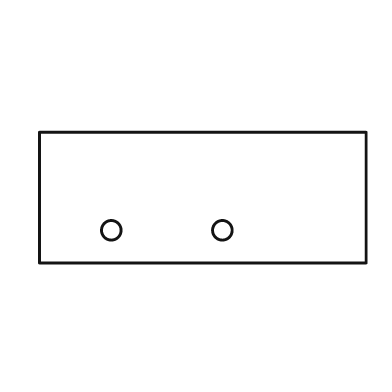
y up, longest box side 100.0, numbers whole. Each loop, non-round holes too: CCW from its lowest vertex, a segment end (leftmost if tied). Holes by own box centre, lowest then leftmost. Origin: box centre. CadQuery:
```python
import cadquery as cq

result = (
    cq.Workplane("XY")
    .moveTo(-50.0, -20.0)
    .lineTo(50.0, -20.0)
    .lineTo(50.0, 20.0)
    .lineTo(-50.0, 20.0)
    .close()
    .moveTo(-28.0, -10.0)
    .circle(3.0)
    .moveTo(6.0, -10.0)
    .circle(3.0)
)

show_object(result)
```